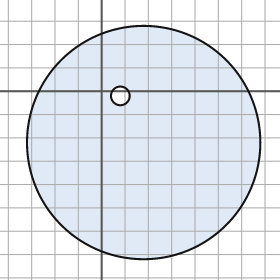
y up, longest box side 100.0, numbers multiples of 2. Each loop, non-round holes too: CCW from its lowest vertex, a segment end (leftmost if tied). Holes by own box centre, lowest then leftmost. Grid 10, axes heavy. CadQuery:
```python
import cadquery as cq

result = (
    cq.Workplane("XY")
    .moveTo(18.0, -22.0)
    .circle(50.0)
    .moveTo(8.0, -2.0)
    .circle(4.0)
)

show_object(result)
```